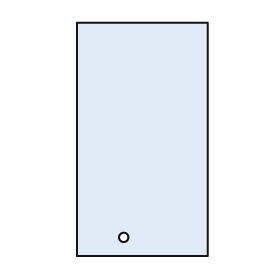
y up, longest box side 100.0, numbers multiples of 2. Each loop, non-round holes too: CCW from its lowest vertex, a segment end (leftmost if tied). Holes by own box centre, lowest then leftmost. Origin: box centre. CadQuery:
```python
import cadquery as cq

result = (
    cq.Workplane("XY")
    .moveTo(-28.0, -50.0)
    .lineTo(28.0, -50.0)
    .lineTo(28.0, 50.0)
    .lineTo(-28.0, 50.0)
    .close()
    .moveTo(-8.0, -42.0)
    .circle(2.0)
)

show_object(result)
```